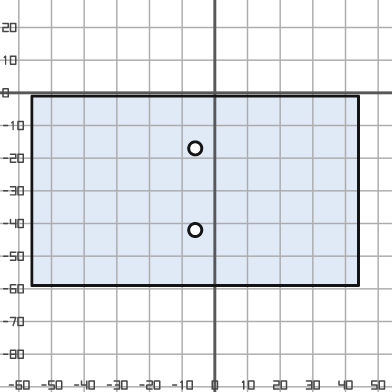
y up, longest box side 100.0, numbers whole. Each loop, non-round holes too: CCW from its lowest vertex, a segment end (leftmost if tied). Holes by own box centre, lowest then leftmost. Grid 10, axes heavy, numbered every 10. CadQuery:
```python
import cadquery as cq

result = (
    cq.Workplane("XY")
    .moveTo(-56.0, -59.0)
    .lineTo(44.0, -59.0)
    .lineTo(44.0, -1.0)
    .lineTo(-56.0, -1.0)
    .close()
    .moveTo(-6.0, -42.0)
    .circle(2.0)
    .moveTo(-6.0, -17.0)
    .circle(2.0)
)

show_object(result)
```